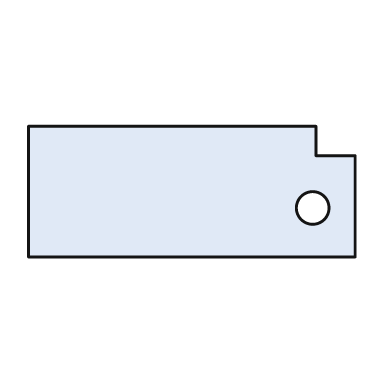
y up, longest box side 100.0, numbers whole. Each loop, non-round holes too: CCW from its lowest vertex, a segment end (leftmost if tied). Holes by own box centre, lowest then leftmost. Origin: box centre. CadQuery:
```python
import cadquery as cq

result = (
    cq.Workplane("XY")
    .moveTo(-50.0, -20.0)
    .lineTo(50.0, -20.0)
    .lineTo(50.0, 11.0)
    .lineTo(38.0, 11.0)
    .lineTo(38.0, 20.0)
    .lineTo(-50.0, 20.0)
    .close()
    .moveTo(37.0, -5.0)
    .circle(5.0)
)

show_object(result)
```